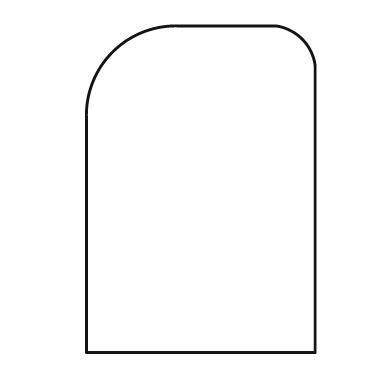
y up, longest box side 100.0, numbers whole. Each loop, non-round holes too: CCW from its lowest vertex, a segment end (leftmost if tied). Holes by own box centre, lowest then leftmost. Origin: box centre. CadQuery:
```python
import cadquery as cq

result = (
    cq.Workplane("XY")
    .moveTo(-35.0, -50.0)
    .lineTo(35.0, -50.0)
    .lineTo(35.0, 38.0)
    .threePointArc((31.0, 46.0), (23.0, 50.0))
    .lineTo(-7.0, 50.0)
    .threePointArc((-27.0, 42.0), (-35.0, 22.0))
    .close()
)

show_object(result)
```